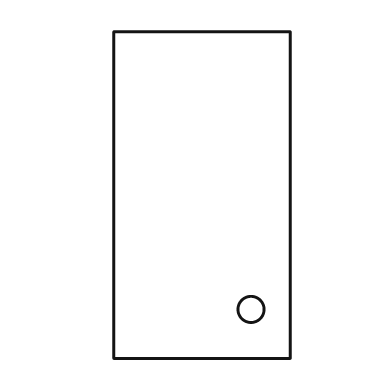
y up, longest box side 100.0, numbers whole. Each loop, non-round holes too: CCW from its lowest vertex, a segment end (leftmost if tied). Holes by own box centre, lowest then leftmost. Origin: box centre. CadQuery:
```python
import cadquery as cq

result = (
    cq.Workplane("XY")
    .moveTo(-27.0, -50.0)
    .lineTo(27.0, -50.0)
    .lineTo(27.0, 50.0)
    .lineTo(-27.0, 50.0)
    .close()
    .moveTo(15.0, -35.0)
    .circle(4.0)
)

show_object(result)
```